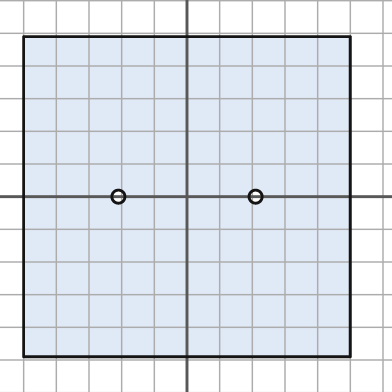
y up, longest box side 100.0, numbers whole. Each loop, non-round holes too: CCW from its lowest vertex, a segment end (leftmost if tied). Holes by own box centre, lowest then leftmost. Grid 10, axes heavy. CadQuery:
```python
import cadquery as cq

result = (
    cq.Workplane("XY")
    .moveTo(-50.0, -49.0)
    .lineTo(50.0, -49.0)
    .lineTo(50.0, 49.0)
    .lineTo(-50.0, 49.0)
    .close()
    .moveTo(-21.0, 0.0)
    .circle(2.0)
    .moveTo(21.0, 0.0)
    .circle(2.0)
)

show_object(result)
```